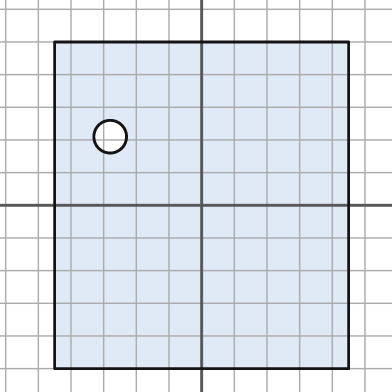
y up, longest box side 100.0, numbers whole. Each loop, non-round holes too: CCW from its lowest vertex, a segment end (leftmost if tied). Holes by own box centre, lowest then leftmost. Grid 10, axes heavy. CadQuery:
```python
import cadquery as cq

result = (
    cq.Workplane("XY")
    .moveTo(-45.0, -50.0)
    .lineTo(45.0, -50.0)
    .lineTo(45.0, 50.0)
    .lineTo(-45.0, 50.0)
    .close()
    .moveTo(-28.0, 21.0)
    .circle(5.0)
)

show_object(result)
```